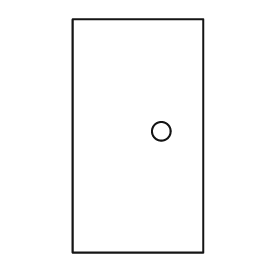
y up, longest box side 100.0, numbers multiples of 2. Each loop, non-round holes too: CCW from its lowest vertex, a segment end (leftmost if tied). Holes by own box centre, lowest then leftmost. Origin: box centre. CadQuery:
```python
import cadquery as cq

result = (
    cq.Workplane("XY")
    .moveTo(-28.0, -50.0)
    .lineTo(28.0, -50.0)
    .lineTo(28.0, 50.0)
    .lineTo(-28.0, 50.0)
    .close()
    .moveTo(10.0, 2.0)
    .circle(4.0)
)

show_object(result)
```